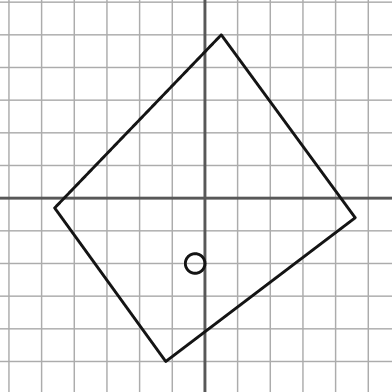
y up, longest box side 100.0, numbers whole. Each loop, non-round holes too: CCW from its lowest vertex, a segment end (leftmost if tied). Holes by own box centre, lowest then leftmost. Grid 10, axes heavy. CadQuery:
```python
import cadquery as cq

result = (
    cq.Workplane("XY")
    .moveTo(-12.0, -50.0)
    .lineTo(46.0, -6.0)
    .lineTo(5.0, 50.0)
    .lineTo(-46.0, -3.0)
    .close()
    .moveTo(-3.0, -20.0)
    .circle(3.0)
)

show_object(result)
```